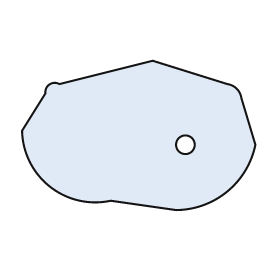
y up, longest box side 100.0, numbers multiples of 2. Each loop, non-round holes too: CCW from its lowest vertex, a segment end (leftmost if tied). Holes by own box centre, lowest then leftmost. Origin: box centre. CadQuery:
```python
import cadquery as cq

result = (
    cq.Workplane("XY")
    .moveTo(16.0, -32.0)
    .threePointArc((38.0, -24.0), (50.0, -4.0))
    .lineTo(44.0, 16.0)
    .threePointArc((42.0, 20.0), (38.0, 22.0))
    .lineTo(6.0, 32.0)
    .lineTo(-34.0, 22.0)
    .threePointArc((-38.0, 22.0), (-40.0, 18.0))
    .lineTo(-50.0, 2.0)
    .threePointArc((-38.0, -22.0), (-12.0, -28.0))
    .close()
    .moveTo(20.0, -4.0)
    .circle(4.0)
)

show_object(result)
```